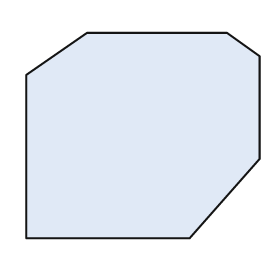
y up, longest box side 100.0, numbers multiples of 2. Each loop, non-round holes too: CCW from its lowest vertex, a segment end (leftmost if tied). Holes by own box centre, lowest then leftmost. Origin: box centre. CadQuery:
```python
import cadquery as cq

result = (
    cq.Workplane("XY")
    .moveTo(-50.0, -44.0)
    .lineTo(20.0, -44.0)
    .lineTo(50.0, -10.0)
    .lineTo(50.0, 34.0)
    .lineTo(36.0, 44.0)
    .lineTo(-24.0, 44.0)
    .lineTo(-50.0, 26.0)
    .close()
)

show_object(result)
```